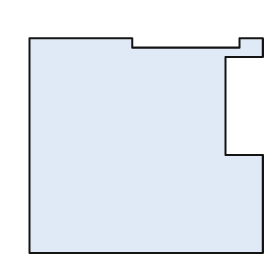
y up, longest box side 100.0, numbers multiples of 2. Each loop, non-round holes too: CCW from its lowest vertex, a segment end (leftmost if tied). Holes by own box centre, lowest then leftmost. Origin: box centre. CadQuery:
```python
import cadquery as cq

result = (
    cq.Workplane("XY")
    .moveTo(-50.0, -46.0)
    .lineTo(50.0, -46.0)
    .lineTo(50.0, -4.0)
    .lineTo(34.0, -4.0)
    .lineTo(34.0, 38.0)
    .lineTo(50.0, 38.0)
    .lineTo(50.0, 46.0)
    .lineTo(40.0, 46.0)
    .lineTo(40.0, 42.0)
    .lineTo(-6.0, 42.0)
    .lineTo(-6.0, 46.0)
    .lineTo(-50.0, 46.0)
    .close()
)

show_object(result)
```